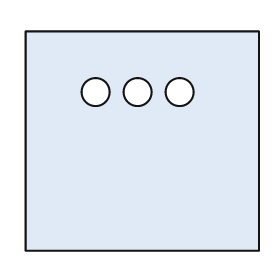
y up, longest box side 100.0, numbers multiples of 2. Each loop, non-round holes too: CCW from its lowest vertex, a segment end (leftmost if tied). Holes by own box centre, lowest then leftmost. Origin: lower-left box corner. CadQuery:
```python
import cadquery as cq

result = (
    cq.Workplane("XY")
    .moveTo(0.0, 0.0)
    .lineTo(100.0, 0.0)
    .lineTo(100.0, 94.0)
    .lineTo(0.0, 94.0)
    .close()
    .moveTo(30.0, 68.0)
    .circle(6.0)
    .moveTo(48.0, 68.0)
    .circle(6.0)
    .moveTo(66.0, 68.0)
    .circle(6.0)
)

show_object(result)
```